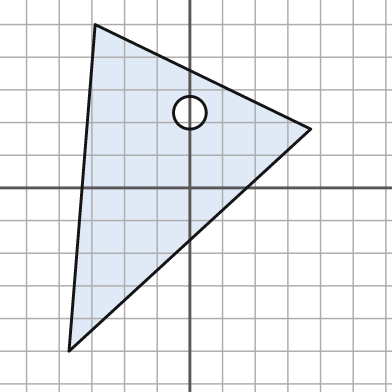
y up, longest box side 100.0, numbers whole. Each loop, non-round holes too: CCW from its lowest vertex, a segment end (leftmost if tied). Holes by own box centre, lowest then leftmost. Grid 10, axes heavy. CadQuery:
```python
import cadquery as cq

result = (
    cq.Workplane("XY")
    .moveTo(-37.0, -50.0)
    .lineTo(37.0, 18.0)
    .lineTo(-29.0, 50.0)
    .close()
    .moveTo(0.0, 23.0)
    .circle(5.0)
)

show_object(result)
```